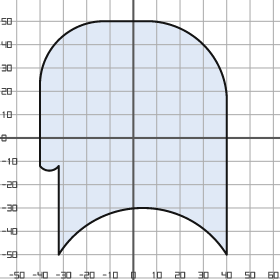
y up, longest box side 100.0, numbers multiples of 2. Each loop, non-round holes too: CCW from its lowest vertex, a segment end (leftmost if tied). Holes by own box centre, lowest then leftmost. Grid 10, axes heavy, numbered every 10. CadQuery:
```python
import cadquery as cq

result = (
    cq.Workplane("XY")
    .moveTo(-32.0, -50.0)
    .threePointArc((4.0, -30.0), (40.0, -50.0))
    .lineTo(40.0, 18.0)
    .threePointArc((30.0, 40.0), (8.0, 50.0))
    .lineTo(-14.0, 50.0)
    .threePointArc((-32.0, 42.0), (-40.0, 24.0))
    .lineTo(-40.0, -12.0)
    .threePointArc((-36.0, -14.0), (-32.0, -12.0))
    .close()
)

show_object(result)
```